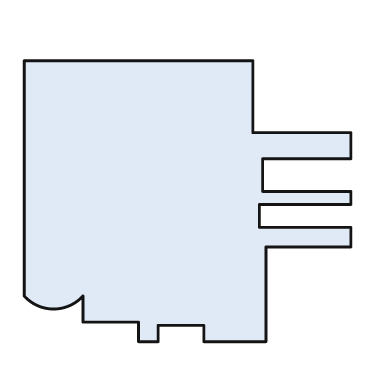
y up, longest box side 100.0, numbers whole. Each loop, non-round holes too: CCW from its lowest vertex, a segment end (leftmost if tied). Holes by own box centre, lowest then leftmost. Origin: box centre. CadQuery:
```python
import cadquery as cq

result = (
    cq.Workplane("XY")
    .moveTo(-15.0, -43.0)
    .lineTo(-9.0, -43.0)
    .lineTo(-9.0, -38.0)
    .lineTo(5.0, -38.0)
    .lineTo(5.0, -43.0)
    .lineTo(24.0, -43.0)
    .lineTo(24.0, -14.0)
    .lineTo(50.0, -14.0)
    .lineTo(50.0, -8.0)
    .lineTo(22.0, -8.0)
    .lineTo(22.0, -1.0)
    .lineTo(50.0, -1.0)
    .lineTo(50.0, 3.0)
    .lineTo(23.0, 3.0)
    .lineTo(23.0, 13.0)
    .lineTo(50.0, 13.0)
    .lineTo(50.0, 21.0)
    .lineTo(20.0, 21.0)
    .lineTo(20.0, 43.0)
    .lineTo(-50.0, 43.0)
    .lineTo(-50.0, -29.0)
    .threePointArc((-41.0, -33.0), (-32.0, -29.0))
    .lineTo(-32.0, -37.0)
    .lineTo(-15.0, -37.0)
    .close()
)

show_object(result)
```